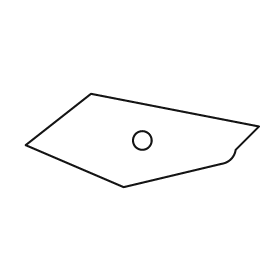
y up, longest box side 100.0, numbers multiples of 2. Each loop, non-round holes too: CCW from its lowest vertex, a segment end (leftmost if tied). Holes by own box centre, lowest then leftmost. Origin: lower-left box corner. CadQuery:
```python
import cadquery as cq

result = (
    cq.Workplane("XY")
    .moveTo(42.0, 0.0)
    .lineTo(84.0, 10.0)
    .threePointArc((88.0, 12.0), (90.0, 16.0))
    .lineTo(100.0, 26.0)
    .lineTo(28.0, 40.0)
    .lineTo(0.0, 18.0)
    .close()
    .moveTo(50.0, 20.0)
    .circle(4.0)
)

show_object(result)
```